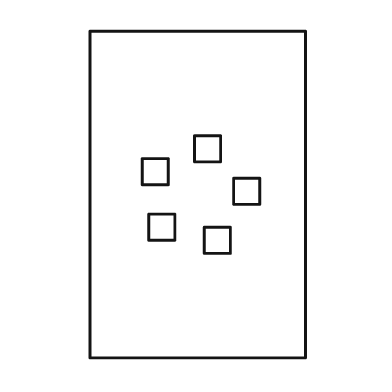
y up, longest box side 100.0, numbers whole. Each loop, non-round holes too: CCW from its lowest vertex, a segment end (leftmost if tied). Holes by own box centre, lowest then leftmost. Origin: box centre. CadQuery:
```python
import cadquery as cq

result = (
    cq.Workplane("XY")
    .moveTo(-33.0, -50.0)
    .lineTo(33.0, -50.0)
    .lineTo(33.0, 50.0)
    .lineTo(-33.0, 50.0)
    .close()
    .moveTo(2.0, -18.0)
    .lineTo(10.0, -18.0)
    .lineTo(10.0, -10.0)
    .lineTo(2.0, -10.0)
    .close()
    .moveTo(-15.0, -14.0)
    .lineTo(-7.0, -14.0)
    .lineTo(-7.0, -6.0)
    .lineTo(-15.0, -6.0)
    .close()
    .moveTo(11.0, -3.0)
    .lineTo(19.0, -3.0)
    .lineTo(19.0, 5.0)
    .lineTo(11.0, 5.0)
    .close()
    .moveTo(-17.0, 3.0)
    .lineTo(-9.0, 3.0)
    .lineTo(-9.0, 11.0)
    .lineTo(-17.0, 11.0)
    .close()
    .moveTo(-1.0, 10.0)
    .lineTo(7.0, 10.0)
    .lineTo(7.0, 18.0)
    .lineTo(-1.0, 18.0)
    .close()
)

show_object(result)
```